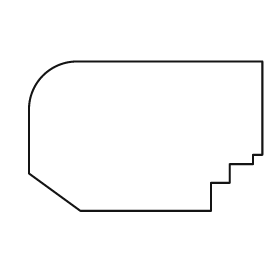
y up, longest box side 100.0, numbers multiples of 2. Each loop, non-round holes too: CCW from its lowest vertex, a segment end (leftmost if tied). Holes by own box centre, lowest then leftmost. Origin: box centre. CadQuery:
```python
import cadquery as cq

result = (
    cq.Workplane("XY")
    .moveTo(-28.0, -32.0)
    .lineTo(28.0, -32.0)
    .lineTo(28.0, -20.0)
    .lineTo(36.0, -20.0)
    .lineTo(36.0, -12.0)
    .lineTo(46.0, -12.0)
    .lineTo(46.0, -8.0)
    .lineTo(50.0, -8.0)
    .lineTo(50.0, 32.0)
    .lineTo(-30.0, 32.0)
    .threePointArc((-44.0, 26.0), (-50.0, 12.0))
    .lineTo(-50.0, -16.0)
    .close()
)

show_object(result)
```